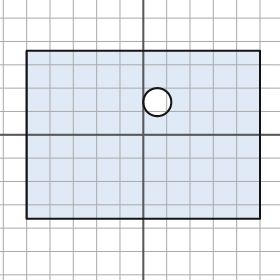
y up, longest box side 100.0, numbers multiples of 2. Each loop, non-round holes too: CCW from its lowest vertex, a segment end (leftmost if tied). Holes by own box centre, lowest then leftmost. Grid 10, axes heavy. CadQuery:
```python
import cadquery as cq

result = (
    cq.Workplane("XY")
    .moveTo(-50.0, -36.0)
    .lineTo(50.0, -36.0)
    .lineTo(50.0, 36.0)
    .lineTo(-50.0, 36.0)
    .close()
    .moveTo(6.0, 14.0)
    .circle(6.0)
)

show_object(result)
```